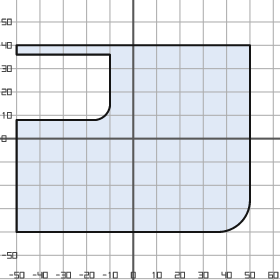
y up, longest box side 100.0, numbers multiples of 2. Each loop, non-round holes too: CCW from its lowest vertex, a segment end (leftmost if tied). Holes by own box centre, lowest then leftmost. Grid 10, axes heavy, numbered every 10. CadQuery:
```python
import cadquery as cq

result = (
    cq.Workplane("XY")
    .moveTo(-50.0, -40.0)
    .lineTo(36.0, -40.0)
    .threePointArc((46.0, -36.0), (50.0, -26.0))
    .lineTo(50.0, 40.0)
    .lineTo(-50.0, 40.0)
    .lineTo(-50.0, 36.0)
    .lineTo(-10.0, 36.0)
    .lineTo(-10.0, 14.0)
    .threePointArc((-12.0, 10.0), (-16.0, 8.0))
    .lineTo(-50.0, 8.0)
    .close()
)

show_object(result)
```